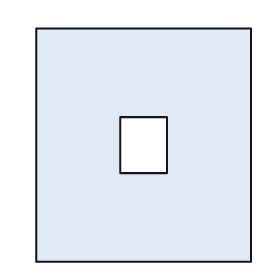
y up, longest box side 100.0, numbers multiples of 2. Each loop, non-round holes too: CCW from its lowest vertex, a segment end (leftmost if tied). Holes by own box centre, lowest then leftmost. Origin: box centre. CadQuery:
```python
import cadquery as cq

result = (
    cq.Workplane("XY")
    .moveTo(-46.0, -50.0)
    .lineTo(46.0, -50.0)
    .lineTo(46.0, 50.0)
    .lineTo(-46.0, 50.0)
    .close()
    .moveTo(-10.0, -12.0)
    .lineTo(10.0, -12.0)
    .lineTo(10.0, 12.0)
    .lineTo(-10.0, 12.0)
    .close()
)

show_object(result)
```